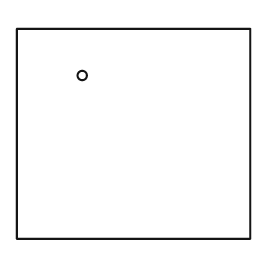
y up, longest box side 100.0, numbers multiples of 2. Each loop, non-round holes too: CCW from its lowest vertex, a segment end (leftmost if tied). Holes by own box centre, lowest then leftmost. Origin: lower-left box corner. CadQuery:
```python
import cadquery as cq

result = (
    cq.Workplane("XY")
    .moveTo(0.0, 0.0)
    .lineTo(100.0, 0.0)
    .lineTo(100.0, 90.0)
    .lineTo(0.0, 90.0)
    .close()
    .moveTo(28.0, 70.0)
    .circle(2.0)
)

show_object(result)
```